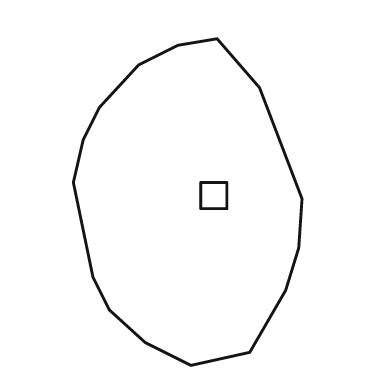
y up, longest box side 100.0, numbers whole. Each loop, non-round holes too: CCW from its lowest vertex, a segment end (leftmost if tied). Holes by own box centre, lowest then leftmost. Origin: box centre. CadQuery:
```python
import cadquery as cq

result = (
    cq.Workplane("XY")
    .moveTo(1.0, -50.0)
    .lineTo(19.0, -46.0)
    .lineTo(30.0, -27.0)
    .lineTo(34.0, -14.0)
    .lineTo(35.0, 1.0)
    .lineTo(22.0, 35.0)
    .lineTo(9.0, 50.0)
    .lineTo(-3.0, 48.0)
    .lineTo(-15.0, 42.0)
    .lineTo(-27.0, 29.0)
    .lineTo(-32.0, 19.0)
    .lineTo(-35.0, 6.0)
    .lineTo(-29.0, -23.0)
    .lineTo(-24.0, -33.0)
    .lineTo(-13.0, -43.0)
    .close()
    .moveTo(4.0, -2.0)
    .lineTo(12.0, -2.0)
    .lineTo(12.0, 6.0)
    .lineTo(4.0, 6.0)
    .close()
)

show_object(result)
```